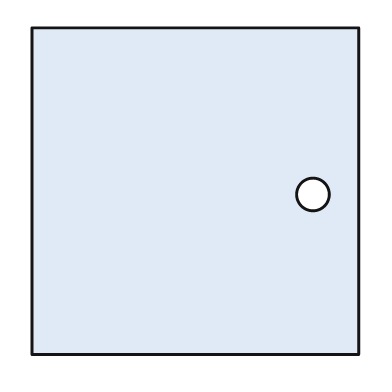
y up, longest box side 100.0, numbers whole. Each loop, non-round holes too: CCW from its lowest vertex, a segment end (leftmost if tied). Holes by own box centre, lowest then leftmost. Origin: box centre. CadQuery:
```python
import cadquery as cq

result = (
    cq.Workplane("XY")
    .moveTo(-50.0, -50.0)
    .lineTo(50.0, -50.0)
    .lineTo(50.0, 50.0)
    .lineTo(-50.0, 50.0)
    .close()
    .moveTo(36.0, -1.0)
    .circle(5.0)
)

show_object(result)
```